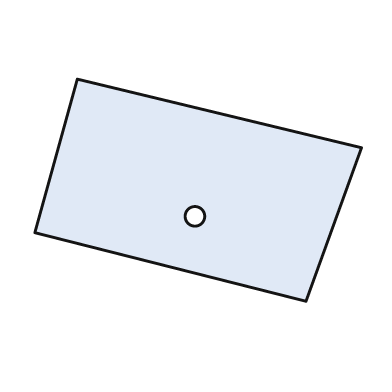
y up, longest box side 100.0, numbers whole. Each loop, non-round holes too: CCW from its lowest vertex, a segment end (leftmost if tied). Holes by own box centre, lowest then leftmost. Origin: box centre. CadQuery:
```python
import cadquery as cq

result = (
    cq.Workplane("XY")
    .moveTo(33.0, -34.0)
    .lineTo(50.0, 13.0)
    .lineTo(-37.0, 34.0)
    .lineTo(-50.0, -13.0)
    .close()
    .moveTo(-1.0, -8.0)
    .circle(3.0)
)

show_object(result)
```